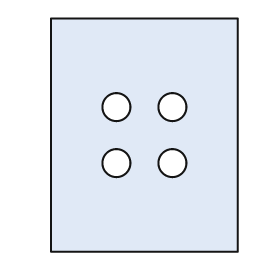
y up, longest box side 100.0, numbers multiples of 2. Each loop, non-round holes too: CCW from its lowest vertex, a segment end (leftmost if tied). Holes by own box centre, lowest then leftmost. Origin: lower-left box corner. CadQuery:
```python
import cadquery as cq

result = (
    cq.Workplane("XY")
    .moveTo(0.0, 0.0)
    .lineTo(80.0, 0.0)
    .lineTo(80.0, 100.0)
    .lineTo(0.0, 100.0)
    .close()
    .moveTo(28.0, 38.0)
    .circle(6.0)
    .moveTo(52.0, 38.0)
    .circle(6.0)
    .moveTo(28.0, 62.0)
    .circle(6.0)
    .moveTo(52.0, 62.0)
    .circle(6.0)
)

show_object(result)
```